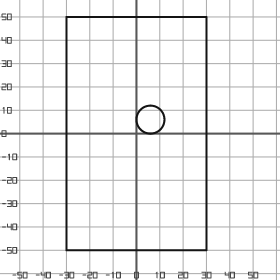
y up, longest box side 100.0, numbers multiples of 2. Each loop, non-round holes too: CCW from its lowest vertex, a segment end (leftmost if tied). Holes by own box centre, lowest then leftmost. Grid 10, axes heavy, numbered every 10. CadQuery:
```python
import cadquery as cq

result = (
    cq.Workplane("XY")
    .moveTo(-30.0, -50.0)
    .lineTo(30.0, -50.0)
    .lineTo(30.0, 50.0)
    .lineTo(-30.0, 50.0)
    .close()
    .moveTo(6.0, 6.0)
    .circle(6.0)
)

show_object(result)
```